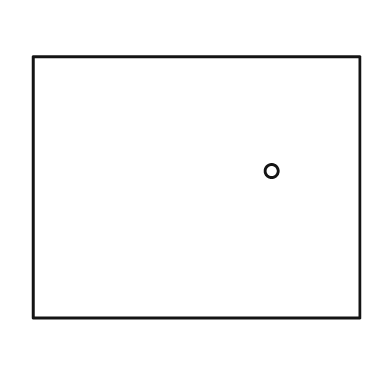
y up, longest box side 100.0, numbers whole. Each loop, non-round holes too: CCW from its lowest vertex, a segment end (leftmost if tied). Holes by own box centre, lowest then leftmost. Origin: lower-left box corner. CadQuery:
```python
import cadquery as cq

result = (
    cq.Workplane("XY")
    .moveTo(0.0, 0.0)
    .lineTo(100.0, 0.0)
    .lineTo(100.0, 80.0)
    .lineTo(0.0, 80.0)
    .close()
    .moveTo(73.0, 45.0)
    .circle(2.0)
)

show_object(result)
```